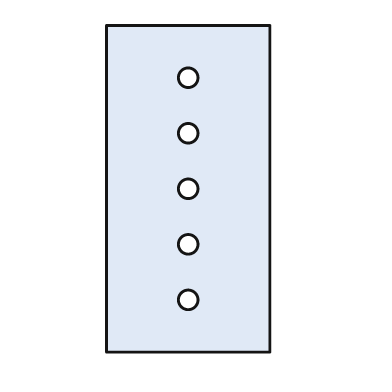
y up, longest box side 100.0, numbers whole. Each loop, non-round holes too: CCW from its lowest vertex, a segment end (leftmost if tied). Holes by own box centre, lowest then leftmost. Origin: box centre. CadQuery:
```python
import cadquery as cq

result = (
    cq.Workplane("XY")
    .moveTo(-25.0, -50.0)
    .lineTo(25.0, -50.0)
    .lineTo(25.0, 50.0)
    .lineTo(-25.0, 50.0)
    .close()
    .moveTo(0.0, -34.0)
    .circle(3.0)
    .moveTo(0.0, -17.0)
    .circle(3.0)
    .moveTo(0.0, 0.0)
    .circle(3.0)
    .moveTo(0.0, 17.0)
    .circle(3.0)
    .moveTo(0.0, 34.0)
    .circle(3.0)
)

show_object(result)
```